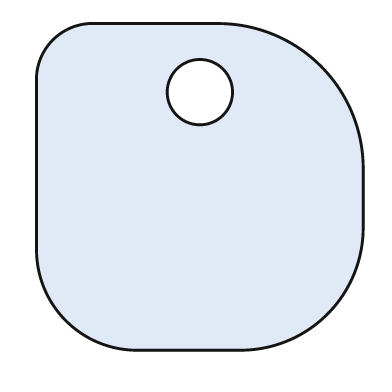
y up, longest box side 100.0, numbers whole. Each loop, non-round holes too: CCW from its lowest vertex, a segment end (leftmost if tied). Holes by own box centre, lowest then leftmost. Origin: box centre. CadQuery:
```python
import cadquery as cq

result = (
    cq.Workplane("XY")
    .moveTo(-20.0, -50.0)
    .lineTo(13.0, -50.0)
    .threePointArc((39.0, -39.0), (50.0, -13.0))
    .lineTo(50.0, 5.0)
    .threePointArc((37.0, 37.0), (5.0, 50.0))
    .lineTo(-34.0, 50.0)
    .threePointArc((-45.0, 45.0), (-50.0, 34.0))
    .lineTo(-50.0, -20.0)
    .threePointArc((-41.0, -41.0), (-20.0, -50.0))
    .close()
    .moveTo(0.0, 29.0)
    .circle(10.0)
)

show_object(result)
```